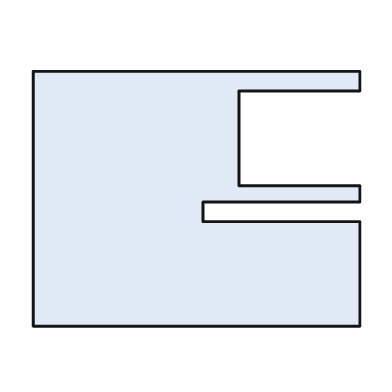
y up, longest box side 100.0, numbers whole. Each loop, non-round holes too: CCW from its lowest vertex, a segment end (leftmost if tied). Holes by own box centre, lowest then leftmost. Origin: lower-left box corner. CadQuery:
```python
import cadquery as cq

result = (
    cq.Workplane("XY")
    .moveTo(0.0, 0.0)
    .lineTo(100.0, 0.0)
    .lineTo(100.0, 32.0)
    .lineTo(52.0, 32.0)
    .lineTo(52.0, 38.0)
    .lineTo(100.0, 38.0)
    .lineTo(100.0, 43.0)
    .lineTo(63.0, 43.0)
    .lineTo(63.0, 72.0)
    .lineTo(100.0, 72.0)
    .lineTo(100.0, 78.0)
    .lineTo(0.0, 78.0)
    .close()
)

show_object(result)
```